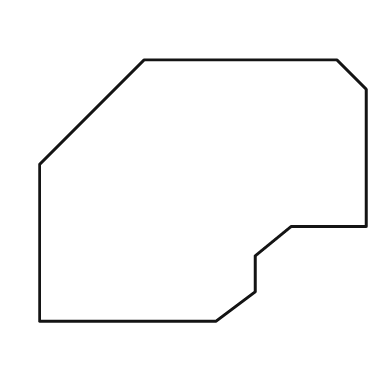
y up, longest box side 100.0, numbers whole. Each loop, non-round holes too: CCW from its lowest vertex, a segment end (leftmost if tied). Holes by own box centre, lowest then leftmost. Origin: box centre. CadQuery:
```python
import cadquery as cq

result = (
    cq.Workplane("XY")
    .moveTo(-50.0, -40.0)
    .lineTo(4.0, -40.0)
    .lineTo(16.0, -31.0)
    .lineTo(16.0, -20.0)
    .lineTo(27.0, -11.0)
    .lineTo(50.0, -11.0)
    .lineTo(50.0, 31.0)
    .lineTo(41.0, 40.0)
    .lineTo(-18.0, 40.0)
    .lineTo(-50.0, 8.0)
    .close()
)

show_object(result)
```